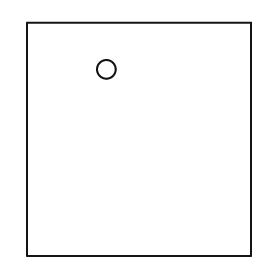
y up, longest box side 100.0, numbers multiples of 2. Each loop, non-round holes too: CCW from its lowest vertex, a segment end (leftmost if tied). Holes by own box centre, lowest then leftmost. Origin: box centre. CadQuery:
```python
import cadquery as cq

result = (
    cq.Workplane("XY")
    .moveTo(-48.0, -50.0)
    .lineTo(48.0, -50.0)
    .lineTo(48.0, 50.0)
    .lineTo(-48.0, 50.0)
    .close()
    .moveTo(-14.0, 30.0)
    .circle(4.0)
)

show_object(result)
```